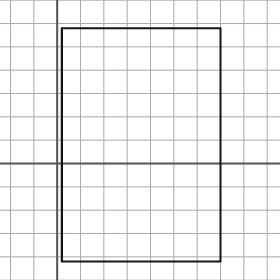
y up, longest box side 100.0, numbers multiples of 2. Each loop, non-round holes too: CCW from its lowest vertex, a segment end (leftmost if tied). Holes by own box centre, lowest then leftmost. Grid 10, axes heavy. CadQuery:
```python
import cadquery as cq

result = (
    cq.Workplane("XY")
    .moveTo(2.0, -42.0)
    .lineTo(70.0, -42.0)
    .lineTo(70.0, 58.0)
    .lineTo(2.0, 58.0)
    .close()
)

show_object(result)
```